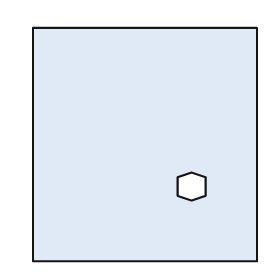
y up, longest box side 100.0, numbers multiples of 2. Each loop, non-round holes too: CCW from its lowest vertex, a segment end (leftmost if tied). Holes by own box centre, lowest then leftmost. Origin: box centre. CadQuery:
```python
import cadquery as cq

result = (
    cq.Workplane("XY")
    .moveTo(-48.0, -50.0)
    .lineTo(48.0, -50.0)
    .lineTo(48.0, 50.0)
    .lineTo(-48.0, 50.0)
    .close()
    .moveTo(20.0, -24.0)
    .lineTo(26.0, -22.0)
    .lineTo(26.0, -14.0)
    .lineTo(20.0, -12.0)
    .lineTo(14.0, -14.0)
    .lineTo(14.0, -22.0)
    .close()
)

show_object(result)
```